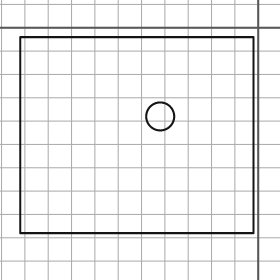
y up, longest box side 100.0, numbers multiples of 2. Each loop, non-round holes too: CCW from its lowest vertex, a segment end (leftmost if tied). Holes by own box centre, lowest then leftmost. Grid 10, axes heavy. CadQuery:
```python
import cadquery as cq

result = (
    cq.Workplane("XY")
    .moveTo(-102.0, -88.0)
    .lineTo(-2.0, -88.0)
    .lineTo(-2.0, -4.0)
    .lineTo(-102.0, -4.0)
    .close()
    .moveTo(-42.0, -38.0)
    .circle(6.0)
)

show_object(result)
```